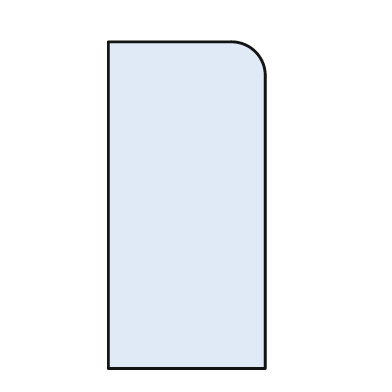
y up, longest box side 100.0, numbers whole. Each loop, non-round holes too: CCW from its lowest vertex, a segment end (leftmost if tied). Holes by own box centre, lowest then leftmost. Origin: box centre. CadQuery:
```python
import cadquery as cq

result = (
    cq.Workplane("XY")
    .moveTo(-24.0, -50.0)
    .lineTo(24.0, -50.0)
    .lineTo(24.0, 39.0)
    .threePointArc((21.0, 47.0), (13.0, 50.0))
    .lineTo(-24.0, 50.0)
    .close()
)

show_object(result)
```